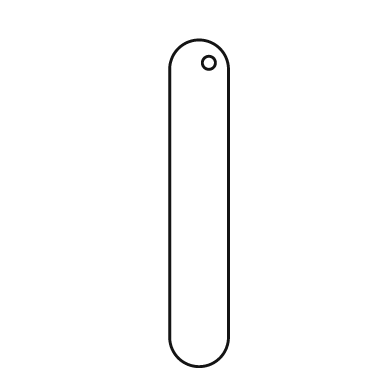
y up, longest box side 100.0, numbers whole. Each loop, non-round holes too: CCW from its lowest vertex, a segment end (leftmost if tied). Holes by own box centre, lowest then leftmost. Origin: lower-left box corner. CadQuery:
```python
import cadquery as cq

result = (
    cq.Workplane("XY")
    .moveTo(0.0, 9.0)
    .threePointArc((9.0, 0.0), (18.0, 9.0))
    .lineTo(18.0, 91.0)
    .threePointArc((9.0, 100.0), (0.0, 91.0))
    .close()
    .moveTo(12.0, 93.0)
    .circle(2.0)
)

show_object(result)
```